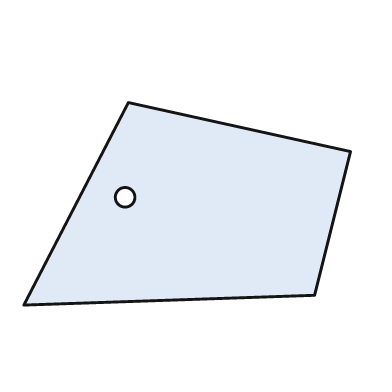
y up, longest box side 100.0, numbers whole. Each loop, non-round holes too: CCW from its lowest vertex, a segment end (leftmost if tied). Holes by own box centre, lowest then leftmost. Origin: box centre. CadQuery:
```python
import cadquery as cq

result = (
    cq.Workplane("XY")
    .moveTo(-50.0, -31.0)
    .lineTo(39.0, -28.0)
    .lineTo(50.0, 16.0)
    .lineTo(-18.0, 31.0)
    .close()
    .moveTo(-19.0, 2.0)
    .circle(3.0)
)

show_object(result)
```